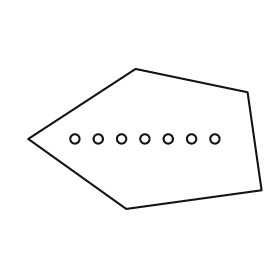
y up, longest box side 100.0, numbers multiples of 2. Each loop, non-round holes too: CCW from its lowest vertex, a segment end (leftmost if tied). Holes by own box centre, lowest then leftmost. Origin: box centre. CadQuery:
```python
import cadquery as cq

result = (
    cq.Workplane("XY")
    .moveTo(-8.0, -30.0)
    .lineTo(50.0, -22.0)
    .lineTo(44.0, 20.0)
    .lineTo(-4.0, 30.0)
    .lineTo(-50.0, 0.0)
    .close()
    .moveTo(-30.0, 0.0)
    .circle(2.0)
    .moveTo(-20.0, 0.0)
    .circle(2.0)
    .moveTo(-10.0, 0.0)
    .circle(2.0)
    .moveTo(0.0, 0.0)
    .circle(2.0)
    .moveTo(10.0, 0.0)
    .circle(2.0)
    .moveTo(20.0, 0.0)
    .circle(2.0)
    .moveTo(30.0, 0.0)
    .circle(2.0)
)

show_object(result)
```